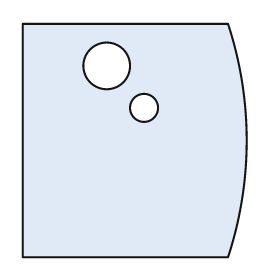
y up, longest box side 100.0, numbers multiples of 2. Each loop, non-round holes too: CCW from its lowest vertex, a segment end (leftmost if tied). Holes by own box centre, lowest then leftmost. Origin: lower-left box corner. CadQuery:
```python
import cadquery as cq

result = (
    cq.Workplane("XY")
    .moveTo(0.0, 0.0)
    .lineTo(88.0, 0.0)
    .threePointArc((96.0, 50.0), (88.0, 100.0))
    .lineTo(0.0, 100.0)
    .close()
    .moveTo(52.0, 64.0)
    .circle(6.0)
    .moveTo(36.0, 82.0)
    .circle(10.0)
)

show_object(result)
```